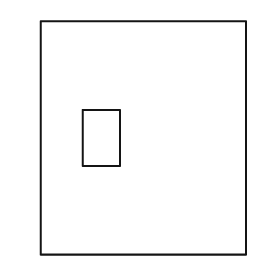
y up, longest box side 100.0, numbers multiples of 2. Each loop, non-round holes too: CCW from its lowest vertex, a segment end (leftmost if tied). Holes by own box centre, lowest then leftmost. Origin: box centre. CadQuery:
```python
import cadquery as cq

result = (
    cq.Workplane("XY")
    .moveTo(-44.0, -50.0)
    .lineTo(44.0, -50.0)
    .lineTo(44.0, 50.0)
    .lineTo(-44.0, 50.0)
    .close()
    .moveTo(-26.0, -12.0)
    .lineTo(-10.0, -12.0)
    .lineTo(-10.0, 12.0)
    .lineTo(-26.0, 12.0)
    .close()
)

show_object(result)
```